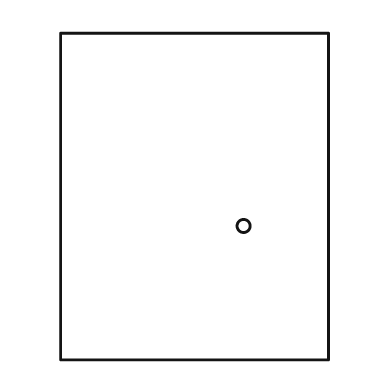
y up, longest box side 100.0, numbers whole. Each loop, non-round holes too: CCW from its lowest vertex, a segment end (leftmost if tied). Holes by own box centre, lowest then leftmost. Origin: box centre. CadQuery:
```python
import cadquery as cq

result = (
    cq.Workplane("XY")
    .moveTo(-41.0, -50.0)
    .lineTo(41.0, -50.0)
    .lineTo(41.0, 50.0)
    .lineTo(-41.0, 50.0)
    .close()
    .moveTo(15.0, -9.0)
    .circle(2.0)
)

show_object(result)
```